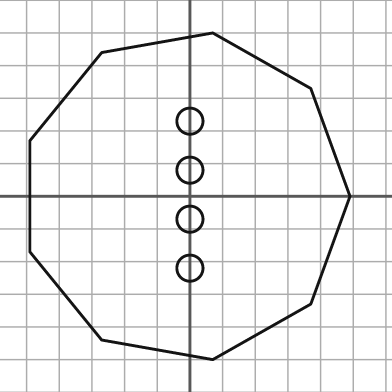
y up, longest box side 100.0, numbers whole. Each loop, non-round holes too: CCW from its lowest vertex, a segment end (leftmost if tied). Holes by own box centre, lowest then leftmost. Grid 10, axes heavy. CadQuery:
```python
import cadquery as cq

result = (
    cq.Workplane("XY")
    .moveTo(7.0, -50.0)
    .lineTo(37.0, -33.0)
    .lineTo(49.0, 0.0)
    .lineTo(37.0, 33.0)
    .lineTo(7.0, 50.0)
    .lineTo(-27.0, 44.0)
    .lineTo(-49.0, 17.0)
    .lineTo(-49.0, -17.0)
    .lineTo(-27.0, -44.0)
    .close()
    .moveTo(0.0, -22.0)
    .circle(4.0)
    .moveTo(0.0, -7.0)
    .circle(4.0)
    .moveTo(0.0, 8.0)
    .circle(4.0)
    .moveTo(0.0, 23.0)
    .circle(4.0)
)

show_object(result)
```